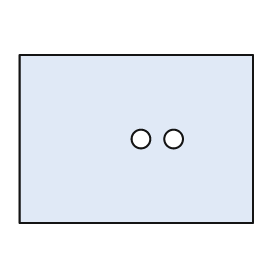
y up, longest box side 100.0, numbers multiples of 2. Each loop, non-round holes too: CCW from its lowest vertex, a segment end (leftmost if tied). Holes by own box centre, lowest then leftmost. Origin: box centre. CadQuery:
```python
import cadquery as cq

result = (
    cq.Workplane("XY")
    .moveTo(-50.0, -36.0)
    .lineTo(50.0, -36.0)
    .lineTo(50.0, 36.0)
    .lineTo(-50.0, 36.0)
    .close()
    .moveTo(2.0, 0.0)
    .circle(4.0)
    .moveTo(16.0, 0.0)
    .circle(4.0)
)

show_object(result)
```